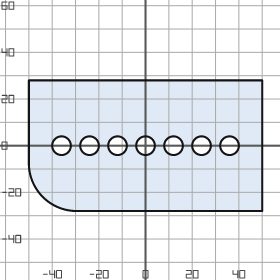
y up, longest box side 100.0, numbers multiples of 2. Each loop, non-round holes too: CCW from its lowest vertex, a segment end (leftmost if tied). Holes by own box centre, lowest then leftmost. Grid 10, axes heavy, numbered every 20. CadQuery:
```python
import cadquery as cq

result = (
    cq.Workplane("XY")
    .moveTo(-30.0, -28.0)
    .lineTo(50.0, -28.0)
    .lineTo(50.0, 28.0)
    .lineTo(-50.0, 28.0)
    .lineTo(-50.0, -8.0)
    .threePointArc((-44.0, -22.0), (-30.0, -28.0))
    .close()
    .moveTo(-36.0, 0.0)
    .circle(4.0)
    .moveTo(-24.0, 0.0)
    .circle(4.0)
    .moveTo(-12.0, 0.0)
    .circle(4.0)
    .moveTo(0.0, 0.0)
    .circle(4.0)
    .moveTo(12.0, 0.0)
    .circle(4.0)
    .moveTo(24.0, 0.0)
    .circle(4.0)
    .moveTo(36.0, 0.0)
    .circle(4.0)
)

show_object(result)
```